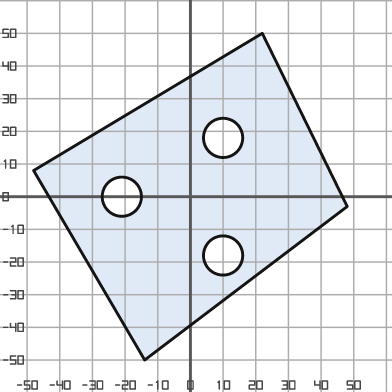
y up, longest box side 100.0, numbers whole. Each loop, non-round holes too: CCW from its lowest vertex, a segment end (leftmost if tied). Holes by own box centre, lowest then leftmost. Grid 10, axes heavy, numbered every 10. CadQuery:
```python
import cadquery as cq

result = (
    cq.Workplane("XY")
    .moveTo(-14.0, -50.0)
    .lineTo(48.0, -3.0)
    .lineTo(22.0, 50.0)
    .lineTo(-48.0, 8.0)
    .close()
    .moveTo(10.0, -18.0)
    .circle(6.0)
    .moveTo(-21.0, 0.0)
    .circle(6.0)
    .moveTo(10.0, 18.0)
    .circle(6.0)
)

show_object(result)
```